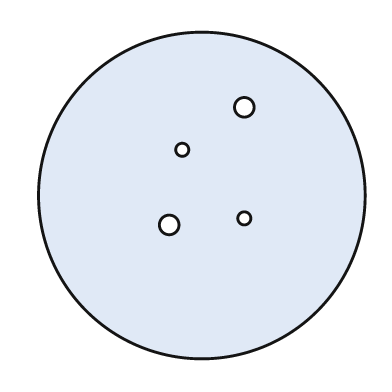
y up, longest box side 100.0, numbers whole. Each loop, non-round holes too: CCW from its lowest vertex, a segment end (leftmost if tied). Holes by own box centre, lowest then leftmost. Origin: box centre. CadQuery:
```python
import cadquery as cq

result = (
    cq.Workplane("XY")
    .moveTo(0.0, 0.0)
    .circle(50.0)
    .moveTo(-10.0, -9.0)
    .circle(3.0)
    .moveTo(13.0, -7.0)
    .circle(2.0)
    .moveTo(-6.0, 14.0)
    .circle(2.0)
    .moveTo(13.0, 27.0)
    .circle(3.0)
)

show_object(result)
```